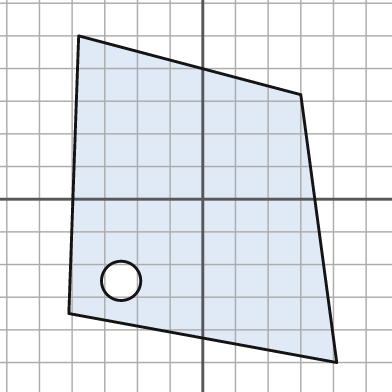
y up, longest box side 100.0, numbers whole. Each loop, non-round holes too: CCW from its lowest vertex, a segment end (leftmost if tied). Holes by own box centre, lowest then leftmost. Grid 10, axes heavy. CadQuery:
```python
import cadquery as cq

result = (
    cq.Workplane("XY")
    .moveTo(41.0, -50.0)
    .lineTo(30.0, 32.0)
    .lineTo(-38.0, 50.0)
    .lineTo(-41.0, -35.0)
    .close()
    .moveTo(-25.0, -25.0)
    .circle(6.0)
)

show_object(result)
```